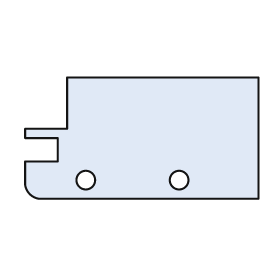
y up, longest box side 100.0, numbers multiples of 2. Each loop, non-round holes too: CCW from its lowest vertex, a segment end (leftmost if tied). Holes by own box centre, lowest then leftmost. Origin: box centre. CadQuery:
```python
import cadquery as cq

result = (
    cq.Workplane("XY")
    .moveTo(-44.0, -26.0)
    .lineTo(50.0, -26.0)
    .lineTo(50.0, 26.0)
    .lineTo(-32.0, 26.0)
    .lineTo(-32.0, 4.0)
    .lineTo(-50.0, 4.0)
    .lineTo(-50.0, 0.0)
    .lineTo(-36.0, 0.0)
    .lineTo(-36.0, -10.0)
    .lineTo(-50.0, -10.0)
    .lineTo(-50.0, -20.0)
    .threePointArc((-48.0, -24.0), (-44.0, -26.0))
    .close()
    .moveTo(-24.0, -18.0)
    .circle(4.0)
    .moveTo(16.0, -18.0)
    .circle(4.0)
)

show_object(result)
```